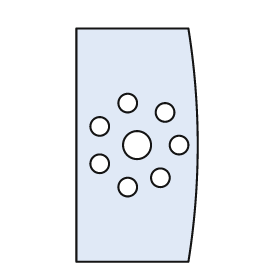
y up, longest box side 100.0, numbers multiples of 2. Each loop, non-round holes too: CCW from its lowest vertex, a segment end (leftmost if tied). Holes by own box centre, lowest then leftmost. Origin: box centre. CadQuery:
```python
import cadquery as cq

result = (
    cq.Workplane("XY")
    .moveTo(-26.0, -50.0)
    .lineTo(22.0, -50.0)
    .threePointArc((26.0, 0.0), (22.0, 50.0))
    .lineTo(-26.0, 50.0)
    .close()
    .moveTo(-4.0, -18.0)
    .circle(4.0)
    .moveTo(10.0, -14.0)
    .circle(4.0)
    .moveTo(-16.0, -8.0)
    .circle(4.0)
    .moveTo(0.0, 0.0)
    .circle(6.0)
    .moveTo(18.0, 0.0)
    .circle(4.0)
    .moveTo(-16.0, 8.0)
    .circle(4.0)
    .moveTo(12.0, 14.0)
    .circle(4.0)
    .moveTo(-4.0, 18.0)
    .circle(4.0)
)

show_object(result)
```